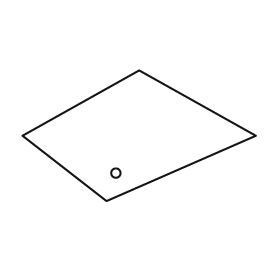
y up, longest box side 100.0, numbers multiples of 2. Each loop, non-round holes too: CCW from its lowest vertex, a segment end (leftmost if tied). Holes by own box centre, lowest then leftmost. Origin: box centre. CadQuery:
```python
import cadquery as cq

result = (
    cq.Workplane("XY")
    .moveTo(-14.0, -28.0)
    .lineTo(50.0, 0.0)
    .lineTo(0.0, 28.0)
    .lineTo(-50.0, 0.0)
    .close()
    .moveTo(-10.0, -16.0)
    .circle(2.0)
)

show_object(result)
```